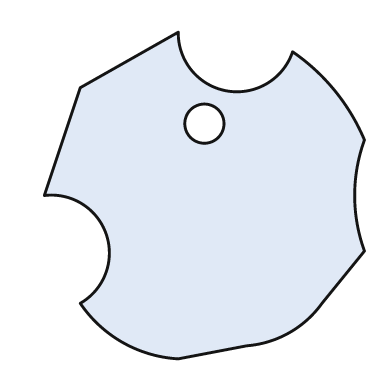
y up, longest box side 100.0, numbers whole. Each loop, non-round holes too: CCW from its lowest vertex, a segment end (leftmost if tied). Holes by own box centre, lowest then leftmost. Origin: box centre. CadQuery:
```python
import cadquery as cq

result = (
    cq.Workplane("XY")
    .moveTo(-8.0, -50.0)
    .lineTo(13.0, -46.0)
    .threePointArc((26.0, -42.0), (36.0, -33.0))
    .lineTo(49.0, -17.0)
    .threePointArc((46.0, 0.0), (49.0, 17.0))
    .threePointArc((40.0, 32.0), (27.0, 44.0))
    .threePointArc((7.0, 32.0), (-8.0, 50.0))
    .lineTo(-38.0, 33.0)
    .lineTo(-49.0, 0.0)
    .threePointArc((-30.0, -12.0), (-38.0, -33.0))
    .threePointArc((-25.0, -45.0), (-8.0, -50.0))
    .close()
    .moveTo(0.0, 22.0)
    .circle(6.0)
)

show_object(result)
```